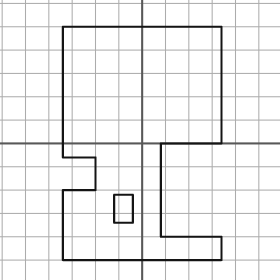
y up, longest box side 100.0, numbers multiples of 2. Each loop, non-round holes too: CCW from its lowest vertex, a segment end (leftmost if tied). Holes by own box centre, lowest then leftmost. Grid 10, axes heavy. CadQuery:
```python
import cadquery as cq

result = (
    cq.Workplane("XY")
    .moveTo(-34.0, -50.0)
    .lineTo(34.0, -50.0)
    .lineTo(34.0, -40.0)
    .lineTo(8.0, -40.0)
    .lineTo(8.0, 0.0)
    .lineTo(34.0, 0.0)
    .lineTo(34.0, 50.0)
    .lineTo(-34.0, 50.0)
    .lineTo(-34.0, -6.0)
    .lineTo(-20.0, -6.0)
    .lineTo(-20.0, -20.0)
    .lineTo(-34.0, -20.0)
    .close()
    .moveTo(-12.0, -34.0)
    .lineTo(-4.0, -34.0)
    .lineTo(-4.0, -22.0)
    .lineTo(-12.0, -22.0)
    .close()
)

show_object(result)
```